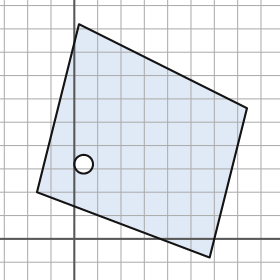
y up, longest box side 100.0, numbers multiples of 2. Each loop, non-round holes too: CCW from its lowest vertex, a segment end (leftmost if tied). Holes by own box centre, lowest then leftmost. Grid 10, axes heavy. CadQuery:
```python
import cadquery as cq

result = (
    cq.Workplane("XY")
    .moveTo(58.0, -8.0)
    .lineTo(74.0, 56.0)
    .lineTo(2.0, 92.0)
    .lineTo(-16.0, 20.0)
    .close()
    .moveTo(4.0, 32.0)
    .circle(4.0)
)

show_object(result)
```